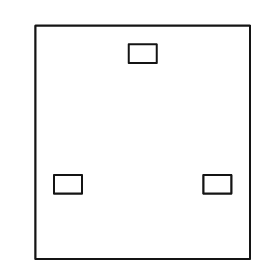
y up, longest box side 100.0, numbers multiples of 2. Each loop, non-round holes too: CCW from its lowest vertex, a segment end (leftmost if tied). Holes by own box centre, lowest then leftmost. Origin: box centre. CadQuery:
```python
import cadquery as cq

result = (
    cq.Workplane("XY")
    .moveTo(-46.0, -50.0)
    .lineTo(46.0, -50.0)
    .lineTo(46.0, 50.0)
    .lineTo(-46.0, 50.0)
    .close()
    .moveTo(-38.0, -22.0)
    .lineTo(-26.0, -22.0)
    .lineTo(-26.0, -14.0)
    .lineTo(-38.0, -14.0)
    .close()
    .moveTo(26.0, -22.0)
    .lineTo(38.0, -22.0)
    .lineTo(38.0, -14.0)
    .lineTo(26.0, -14.0)
    .close()
    .moveTo(-6.0, 34.0)
    .lineTo(6.0, 34.0)
    .lineTo(6.0, 42.0)
    .lineTo(-6.0, 42.0)
    .close()
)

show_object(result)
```